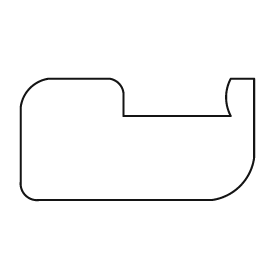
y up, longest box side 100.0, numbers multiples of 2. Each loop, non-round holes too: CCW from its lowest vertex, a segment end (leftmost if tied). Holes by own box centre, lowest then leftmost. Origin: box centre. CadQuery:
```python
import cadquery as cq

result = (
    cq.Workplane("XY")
    .moveTo(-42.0, -26.0)
    .lineTo(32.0, -26.0)
    .threePointArc((44.0, -20.0), (50.0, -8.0))
    .lineTo(50.0, 26.0)
    .lineTo(40.0, 26.0)
    .threePointArc((38.0, 18.0), (40.0, 10.0))
    .lineTo(-6.0, 10.0)
    .lineTo(-6.0, 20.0)
    .threePointArc((-8.0, 24.0), (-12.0, 26.0))
    .lineTo(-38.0, 26.0)
    .threePointArc((-46.0, 22.0), (-50.0, 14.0))
    .lineTo(-50.0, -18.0)
    .threePointArc((-48.0, -24.0), (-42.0, -26.0))
    .close()
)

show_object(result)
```